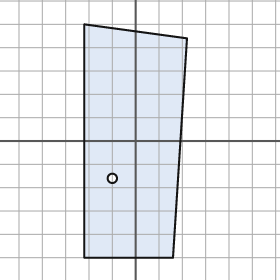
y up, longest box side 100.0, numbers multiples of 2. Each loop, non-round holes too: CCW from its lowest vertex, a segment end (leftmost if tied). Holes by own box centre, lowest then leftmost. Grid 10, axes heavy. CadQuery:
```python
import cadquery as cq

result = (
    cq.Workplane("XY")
    .moveTo(-22.0, -50.0)
    .lineTo(16.0, -50.0)
    .lineTo(22.0, 44.0)
    .lineTo(-22.0, 50.0)
    .close()
    .moveTo(-10.0, -16.0)
    .circle(2.0)
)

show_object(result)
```